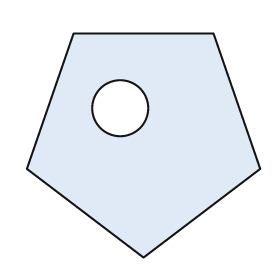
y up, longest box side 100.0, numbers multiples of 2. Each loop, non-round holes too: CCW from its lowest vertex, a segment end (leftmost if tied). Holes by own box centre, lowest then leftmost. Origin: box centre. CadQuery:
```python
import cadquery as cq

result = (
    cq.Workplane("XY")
    .moveTo(0.0, -48.0)
    .lineTo(50.0, -10.0)
    .lineTo(30.0, 48.0)
    .lineTo(-30.0, 48.0)
    .lineTo(-50.0, -10.0)
    .close()
    .moveTo(-10.0, 16.0)
    .circle(12.0)
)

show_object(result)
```